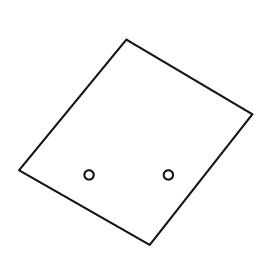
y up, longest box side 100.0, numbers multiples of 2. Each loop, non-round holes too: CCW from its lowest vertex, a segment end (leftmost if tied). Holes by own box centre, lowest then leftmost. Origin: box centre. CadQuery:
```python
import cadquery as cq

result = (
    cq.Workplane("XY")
    .moveTo(6.0, -44.0)
    .lineTo(50.0, 12.0)
    .lineTo(-4.0, 44.0)
    .lineTo(-50.0, -12.0)
    .close()
    .moveTo(-20.0, -14.0)
    .circle(2.0)
    .moveTo(14.0, -14.0)
    .circle(2.0)
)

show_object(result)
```